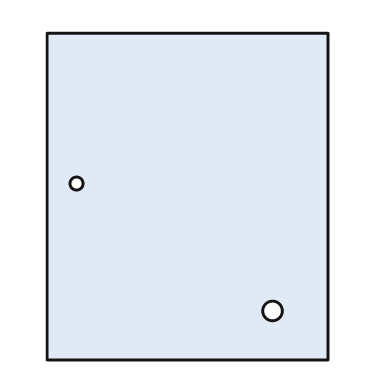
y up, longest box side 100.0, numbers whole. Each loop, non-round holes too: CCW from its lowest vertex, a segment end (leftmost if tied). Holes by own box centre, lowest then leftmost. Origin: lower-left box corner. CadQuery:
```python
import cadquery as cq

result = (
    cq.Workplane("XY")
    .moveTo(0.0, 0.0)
    .lineTo(86.0, 0.0)
    .lineTo(86.0, 100.0)
    .lineTo(0.0, 100.0)
    .close()
    .moveTo(69.0, 15.0)
    .circle(3.0)
    .moveTo(9.0, 54.0)
    .circle(2.0)
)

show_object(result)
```